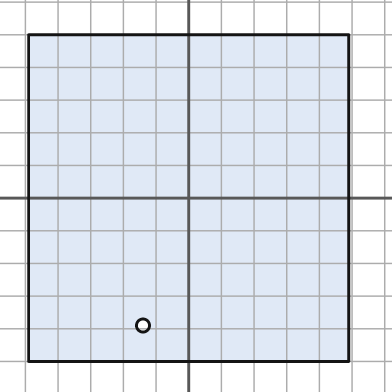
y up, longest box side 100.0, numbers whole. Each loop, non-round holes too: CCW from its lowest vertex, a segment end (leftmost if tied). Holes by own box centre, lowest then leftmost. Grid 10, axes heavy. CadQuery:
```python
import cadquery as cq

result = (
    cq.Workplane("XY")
    .moveTo(-49.0, -50.0)
    .lineTo(49.0, -50.0)
    .lineTo(49.0, 50.0)
    .lineTo(-49.0, 50.0)
    .close()
    .moveTo(-14.0, -39.0)
    .circle(2.0)
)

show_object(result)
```